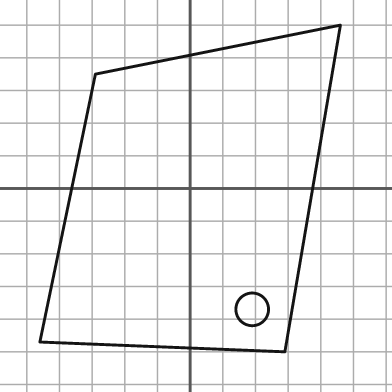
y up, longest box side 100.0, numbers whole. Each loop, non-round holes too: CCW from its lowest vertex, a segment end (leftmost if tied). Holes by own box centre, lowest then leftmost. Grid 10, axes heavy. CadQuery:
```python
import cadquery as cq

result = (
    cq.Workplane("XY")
    .moveTo(29.0, -50.0)
    .lineTo(46.0, 50.0)
    .lineTo(-29.0, 35.0)
    .lineTo(-46.0, -47.0)
    .close()
    .moveTo(19.0, -37.0)
    .circle(5.0)
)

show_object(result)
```